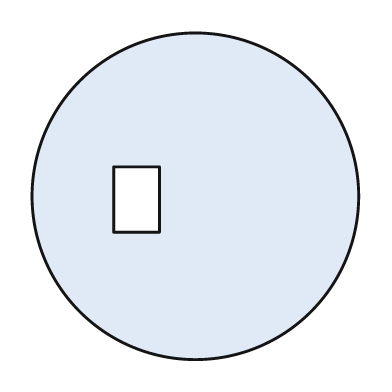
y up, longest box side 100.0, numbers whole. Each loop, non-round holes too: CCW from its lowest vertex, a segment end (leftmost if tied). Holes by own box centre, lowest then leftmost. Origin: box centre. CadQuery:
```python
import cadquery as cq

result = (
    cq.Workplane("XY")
    .moveTo(0.0, 0.0)
    .circle(50.0)
    .moveTo(-25.0, -11.0)
    .lineTo(-11.0, -11.0)
    .lineTo(-11.0, 9.0)
    .lineTo(-25.0, 9.0)
    .close()
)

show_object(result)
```